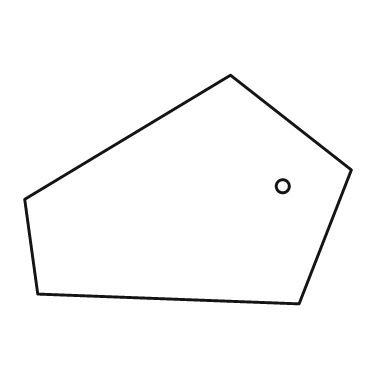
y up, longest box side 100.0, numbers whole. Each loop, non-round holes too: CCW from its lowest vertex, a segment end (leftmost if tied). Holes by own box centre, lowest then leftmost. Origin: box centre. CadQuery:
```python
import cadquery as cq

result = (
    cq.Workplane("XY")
    .moveTo(34.0, -35.0)
    .lineTo(50.0, 6.0)
    .lineTo(13.0, 35.0)
    .lineTo(-50.0, -3.0)
    .lineTo(-46.0, -32.0)
    .close()
    .moveTo(29.0, 1.0)
    .circle(2.0)
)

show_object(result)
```